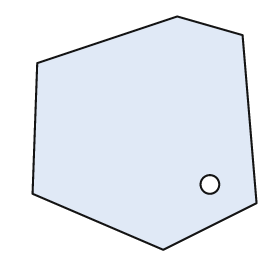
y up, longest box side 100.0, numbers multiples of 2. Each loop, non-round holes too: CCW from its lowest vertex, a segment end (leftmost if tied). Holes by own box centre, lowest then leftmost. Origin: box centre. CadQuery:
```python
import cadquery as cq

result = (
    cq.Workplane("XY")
    .moveTo(8.0, -50.0)
    .lineTo(48.0, -30.0)
    .lineTo(42.0, 42.0)
    .lineTo(14.0, 50.0)
    .lineTo(-46.0, 30.0)
    .lineTo(-48.0, -26.0)
    .close()
    .moveTo(28.0, -22.0)
    .circle(4.0)
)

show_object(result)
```